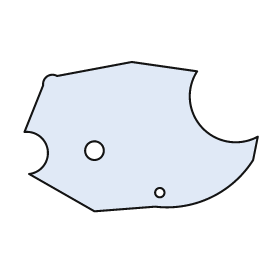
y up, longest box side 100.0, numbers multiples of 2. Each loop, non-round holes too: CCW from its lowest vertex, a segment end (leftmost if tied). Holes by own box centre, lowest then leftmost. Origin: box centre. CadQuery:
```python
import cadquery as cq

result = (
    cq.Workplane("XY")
    .moveTo(-20.0, -32.0)
    .lineTo(6.0, -30.0)
    .threePointArc((30.0, -26.0), (48.0, -10.0))
    .lineTo(50.0, 0.0)
    .threePointArc((26.0, 4.0), (24.0, 28.0))
    .lineTo(-4.0, 32.0)
    .lineTo(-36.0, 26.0)
    .threePointArc((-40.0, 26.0), (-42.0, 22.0))
    .lineTo(-50.0, 2.0)
    .threePointArc((-40.0, -6.0), (-48.0, -16.0))
    .close()
    .moveTo(8.0, -24.0)
    .circle(2.0)
    .moveTo(-20.0, -6.0)
    .circle(4.0)
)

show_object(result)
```